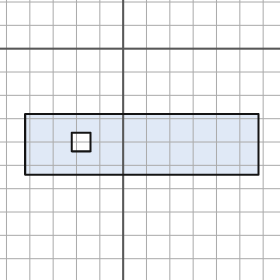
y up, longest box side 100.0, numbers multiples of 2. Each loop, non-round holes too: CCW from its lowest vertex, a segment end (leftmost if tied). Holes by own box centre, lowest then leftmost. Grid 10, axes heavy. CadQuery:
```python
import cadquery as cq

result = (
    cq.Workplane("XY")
    .moveTo(-42.0, -54.0)
    .lineTo(58.0, -54.0)
    .lineTo(58.0, -28.0)
    .lineTo(-42.0, -28.0)
    .close()
    .moveTo(-22.0, -44.0)
    .lineTo(-14.0, -44.0)
    .lineTo(-14.0, -36.0)
    .lineTo(-22.0, -36.0)
    .close()
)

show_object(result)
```